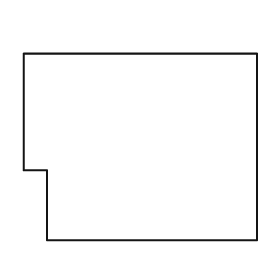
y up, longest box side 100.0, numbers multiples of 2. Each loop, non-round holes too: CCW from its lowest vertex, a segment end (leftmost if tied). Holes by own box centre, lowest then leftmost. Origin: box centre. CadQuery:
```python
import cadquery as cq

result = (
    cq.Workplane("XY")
    .moveTo(-40.0, -40.0)
    .lineTo(50.0, -40.0)
    .lineTo(50.0, 40.0)
    .lineTo(-50.0, 40.0)
    .lineTo(-50.0, -10.0)
    .lineTo(-40.0, -10.0)
    .close()
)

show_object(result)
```